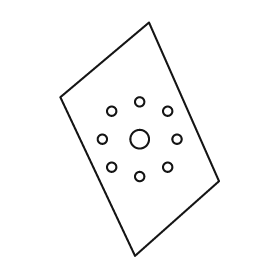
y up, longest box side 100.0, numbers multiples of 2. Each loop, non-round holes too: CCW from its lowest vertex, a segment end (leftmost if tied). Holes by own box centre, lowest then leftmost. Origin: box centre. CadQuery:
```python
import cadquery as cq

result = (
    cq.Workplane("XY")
    .moveTo(-2.0, -50.0)
    .lineTo(34.0, -18.0)
    .lineTo(4.0, 50.0)
    .lineTo(-34.0, 18.0)
    .close()
    .moveTo(0.0, -16.0)
    .circle(2.0)
    .moveTo(-12.0, -12.0)
    .circle(2.0)
    .moveTo(12.0, -12.0)
    .circle(2.0)
    .moveTo(-16.0, 0.0)
    .circle(2.0)
    .moveTo(0.0, 0.0)
    .circle(4.0)
    .moveTo(16.0, 0.0)
    .circle(2.0)
    .moveTo(-12.0, 12.0)
    .circle(2.0)
    .moveTo(12.0, 12.0)
    .circle(2.0)
    .moveTo(0.0, 16.0)
    .circle(2.0)
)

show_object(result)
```